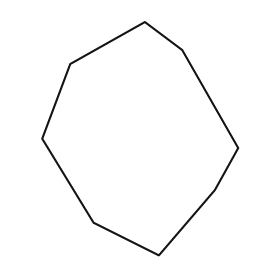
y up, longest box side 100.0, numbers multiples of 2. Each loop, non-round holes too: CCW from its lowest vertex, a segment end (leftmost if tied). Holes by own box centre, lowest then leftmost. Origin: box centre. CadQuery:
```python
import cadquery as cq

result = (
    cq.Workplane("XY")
    .moveTo(8.0, -50.0)
    .lineTo(32.0, -22.0)
    .lineTo(42.0, -4.0)
    .lineTo(18.0, 38.0)
    .lineTo(2.0, 50.0)
    .lineTo(-30.0, 32.0)
    .lineTo(-42.0, 0.0)
    .lineTo(-20.0, -36.0)
    .close()
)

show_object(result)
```